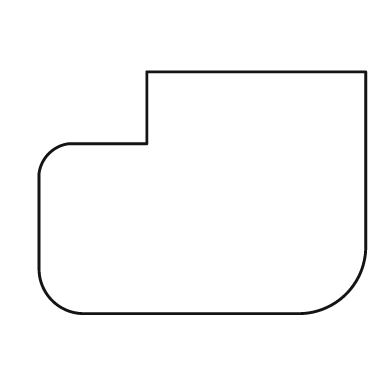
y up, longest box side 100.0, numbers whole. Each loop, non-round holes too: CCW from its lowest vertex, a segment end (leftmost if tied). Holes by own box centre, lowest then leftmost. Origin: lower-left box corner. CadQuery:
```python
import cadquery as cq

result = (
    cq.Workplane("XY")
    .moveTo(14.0, 0.0)
    .lineTo(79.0, 0.0)
    .threePointArc((94.0, 6.0), (100.0, 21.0))
    .lineTo(100.0, 74.0)
    .lineTo(33.0, 74.0)
    .lineTo(33.0, 52.0)
    .lineTo(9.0, 52.0)
    .threePointArc((3.0, 49.0), (0.0, 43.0))
    .lineTo(0.0, 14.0)
    .threePointArc((4.0, 4.0), (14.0, 0.0))
    .close()
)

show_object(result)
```